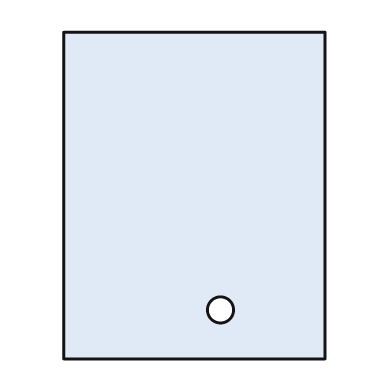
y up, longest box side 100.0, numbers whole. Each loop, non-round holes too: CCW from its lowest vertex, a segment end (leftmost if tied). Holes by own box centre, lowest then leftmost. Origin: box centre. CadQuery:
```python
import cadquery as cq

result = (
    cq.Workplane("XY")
    .moveTo(-40.0, -50.0)
    .lineTo(40.0, -50.0)
    .lineTo(40.0, 50.0)
    .lineTo(-40.0, 50.0)
    .close()
    .moveTo(8.0, -35.0)
    .circle(4.0)
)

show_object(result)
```